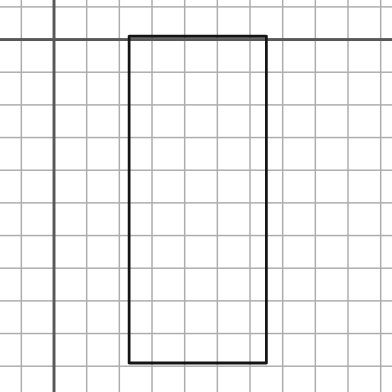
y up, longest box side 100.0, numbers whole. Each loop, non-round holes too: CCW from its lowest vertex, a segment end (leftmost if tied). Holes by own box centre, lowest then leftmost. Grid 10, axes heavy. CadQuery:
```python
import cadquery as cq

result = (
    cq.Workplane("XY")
    .moveTo(23.0, -99.0)
    .lineTo(65.0, -99.0)
    .lineTo(65.0, 1.0)
    .lineTo(23.0, 1.0)
    .close()
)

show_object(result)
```